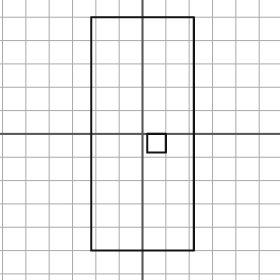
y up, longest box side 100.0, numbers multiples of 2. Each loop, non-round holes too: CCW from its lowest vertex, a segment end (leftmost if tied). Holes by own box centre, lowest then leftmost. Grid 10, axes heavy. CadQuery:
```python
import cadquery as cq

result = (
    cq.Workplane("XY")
    .moveTo(-22.0, -50.0)
    .lineTo(22.0, -50.0)
    .lineTo(22.0, 50.0)
    .lineTo(-22.0, 50.0)
    .close()
    .moveTo(2.0, -8.0)
    .lineTo(10.0, -8.0)
    .lineTo(10.0, 0.0)
    .lineTo(2.0, 0.0)
    .close()
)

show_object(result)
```